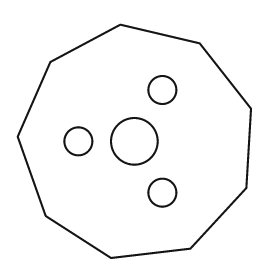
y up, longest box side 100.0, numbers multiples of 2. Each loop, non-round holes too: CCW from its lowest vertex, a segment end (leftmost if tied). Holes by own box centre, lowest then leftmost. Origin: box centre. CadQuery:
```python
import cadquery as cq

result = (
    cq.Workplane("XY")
    .moveTo(-10.0, -50.0)
    .lineTo(24.0, -46.0)
    .lineTo(48.0, -20.0)
    .lineTo(50.0, 14.0)
    .lineTo(28.0, 42.0)
    .lineTo(-6.0, 50.0)
    .lineTo(-36.0, 34.0)
    .lineTo(-50.0, 2.0)
    .lineTo(-38.0, -32.0)
    .close()
    .moveTo(12.0, -22.0)
    .circle(6.0)
    .moveTo(-24.0, 0.0)
    .circle(6.0)
    .moveTo(0.0, 0.0)
    .circle(10.0)
    .moveTo(12.0, 22.0)
    .circle(6.0)
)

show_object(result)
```